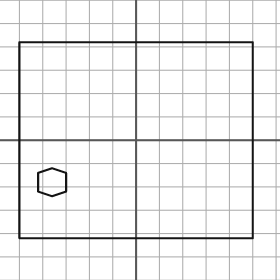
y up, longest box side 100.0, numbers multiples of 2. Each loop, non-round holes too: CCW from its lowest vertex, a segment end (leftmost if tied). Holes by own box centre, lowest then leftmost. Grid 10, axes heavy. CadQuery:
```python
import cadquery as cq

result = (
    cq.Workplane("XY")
    .moveTo(-50.0, -42.0)
    .lineTo(50.0, -42.0)
    .lineTo(50.0, 42.0)
    .lineTo(-50.0, 42.0)
    .close()
    .moveTo(-36.0, -24.0)
    .lineTo(-30.0, -22.0)
    .lineTo(-30.0, -14.0)
    .lineTo(-36.0, -12.0)
    .lineTo(-42.0, -14.0)
    .lineTo(-42.0, -22.0)
    .close()
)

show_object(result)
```